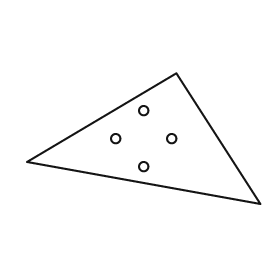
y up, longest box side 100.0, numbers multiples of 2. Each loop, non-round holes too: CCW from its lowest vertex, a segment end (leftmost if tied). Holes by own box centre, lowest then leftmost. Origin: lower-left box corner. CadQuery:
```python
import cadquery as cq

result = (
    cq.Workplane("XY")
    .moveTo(100.0, 0.0)
    .lineTo(64.0, 56.0)
    .lineTo(0.0, 18.0)
    .close()
    .moveTo(50.0, 16.0)
    .circle(2.0)
    .moveTo(38.0, 28.0)
    .circle(2.0)
    .moveTo(62.0, 28.0)
    .circle(2.0)
    .moveTo(50.0, 40.0)
    .circle(2.0)
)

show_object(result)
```